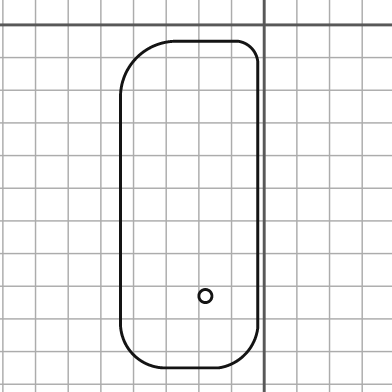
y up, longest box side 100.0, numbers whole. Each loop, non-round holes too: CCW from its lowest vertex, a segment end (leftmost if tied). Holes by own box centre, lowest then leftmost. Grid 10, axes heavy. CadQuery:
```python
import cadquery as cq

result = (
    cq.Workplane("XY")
    .moveTo(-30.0, -105.0)
    .lineTo(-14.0, -105.0)
    .threePointArc((-6.0, -101.0), (-2.0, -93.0))
    .lineTo(-2.0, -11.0)
    .threePointArc((-4.0, -7.0), (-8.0, -5.0))
    .lineTo(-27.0, -5.0)
    .threePointArc((-39.0, -10.0), (-44.0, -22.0))
    .lineTo(-44.0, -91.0)
    .threePointArc((-40.0, -101.0), (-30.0, -105.0))
    .close()
    .moveTo(-18.0, -83.0)
    .circle(2.0)
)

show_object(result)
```